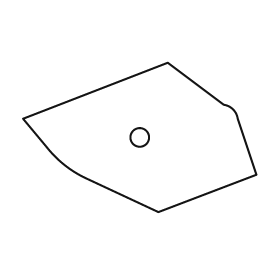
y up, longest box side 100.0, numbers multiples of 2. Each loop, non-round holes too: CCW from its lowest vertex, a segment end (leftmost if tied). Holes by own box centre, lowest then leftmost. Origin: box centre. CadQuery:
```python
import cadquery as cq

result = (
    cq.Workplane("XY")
    .moveTo(8.0, -32.0)
    .lineTo(50.0, -16.0)
    .lineTo(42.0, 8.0)
    .threePointArc((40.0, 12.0), (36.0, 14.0))
    .lineTo(12.0, 32.0)
    .lineTo(-50.0, 8.0)
    .lineTo(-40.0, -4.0)
    .threePointArc((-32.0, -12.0), (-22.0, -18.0))
    .close()
    .moveTo(0.0, 0.0)
    .circle(4.0)
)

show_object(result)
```